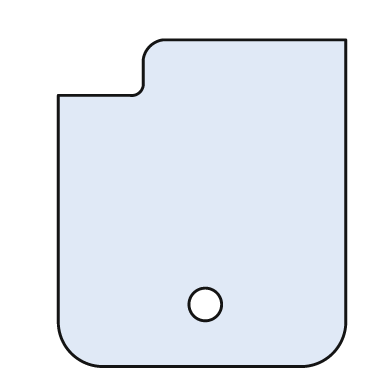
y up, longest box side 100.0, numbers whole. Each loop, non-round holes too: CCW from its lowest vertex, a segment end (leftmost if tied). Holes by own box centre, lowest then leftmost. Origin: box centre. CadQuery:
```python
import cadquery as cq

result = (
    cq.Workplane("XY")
    .moveTo(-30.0, -50.0)
    .lineTo(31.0, -50.0)
    .threePointArc((40.0, -46.0), (44.0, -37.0))
    .lineTo(44.0, 50.0)
    .lineTo(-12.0, 50.0)
    .threePointArc((-16.0, 48.0), (-18.0, 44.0))
    .lineTo(-18.0, 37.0)
    .threePointArc((-19.0, 34.0), (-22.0, 33.0))
    .lineTo(-44.0, 33.0)
    .lineTo(-44.0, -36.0)
    .threePointArc((-40.0, -46.0), (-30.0, -50.0))
    .close()
    .moveTo(1.0, -31.0)
    .circle(5.0)
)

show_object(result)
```